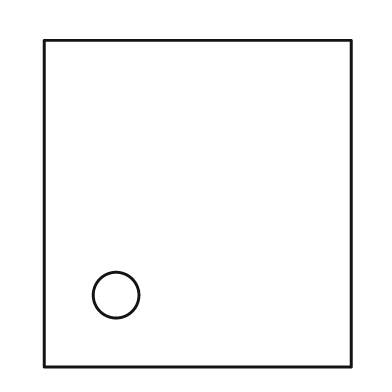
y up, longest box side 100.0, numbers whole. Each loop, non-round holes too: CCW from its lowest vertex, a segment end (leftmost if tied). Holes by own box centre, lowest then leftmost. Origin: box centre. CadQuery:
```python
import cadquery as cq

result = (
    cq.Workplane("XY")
    .moveTo(-47.0, -50.0)
    .lineTo(47.0, -50.0)
    .lineTo(47.0, 50.0)
    .lineTo(-47.0, 50.0)
    .close()
    .moveTo(-25.0, -28.0)
    .circle(7.0)
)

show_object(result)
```